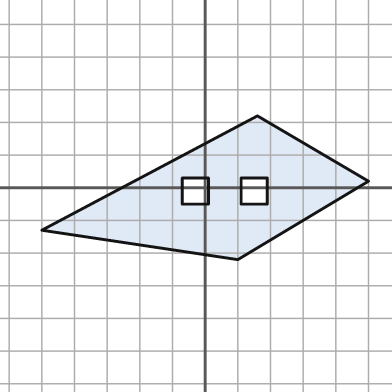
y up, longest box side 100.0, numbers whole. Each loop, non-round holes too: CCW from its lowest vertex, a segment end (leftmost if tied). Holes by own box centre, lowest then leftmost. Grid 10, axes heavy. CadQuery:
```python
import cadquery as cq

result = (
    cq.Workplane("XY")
    .moveTo(10.0, -22.0)
    .lineTo(50.0, 2.0)
    .lineTo(16.0, 22.0)
    .lineTo(-50.0, -13.0)
    .close()
    .moveTo(-7.0, -5.0)
    .lineTo(1.0, -5.0)
    .lineTo(1.0, 3.0)
    .lineTo(-7.0, 3.0)
    .close()
    .moveTo(11.0, -5.0)
    .lineTo(19.0, -5.0)
    .lineTo(19.0, 3.0)
    .lineTo(11.0, 3.0)
    .close()
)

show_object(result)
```